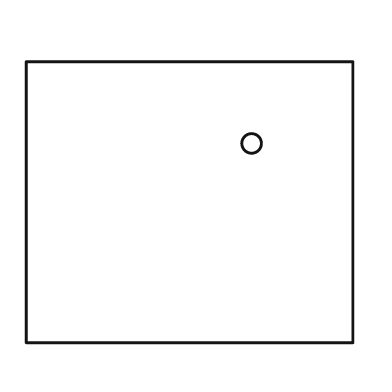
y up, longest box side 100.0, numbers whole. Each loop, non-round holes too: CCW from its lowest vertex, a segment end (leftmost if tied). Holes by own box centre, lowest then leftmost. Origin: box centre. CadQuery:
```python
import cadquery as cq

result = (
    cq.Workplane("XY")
    .moveTo(-50.0, -43.0)
    .lineTo(50.0, -43.0)
    .lineTo(50.0, 43.0)
    .lineTo(-50.0, 43.0)
    .close()
    .moveTo(19.0, 18.0)
    .circle(3.0)
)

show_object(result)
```